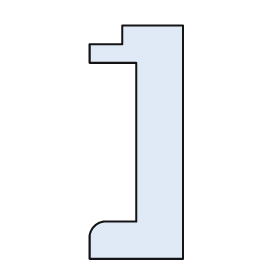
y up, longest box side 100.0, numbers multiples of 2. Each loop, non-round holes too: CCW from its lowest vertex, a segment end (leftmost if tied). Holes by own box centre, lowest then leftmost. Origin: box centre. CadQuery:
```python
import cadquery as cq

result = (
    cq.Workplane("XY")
    .moveTo(-20.0, -50.0)
    .lineTo(20.0, -50.0)
    .lineTo(20.0, 50.0)
    .lineTo(-6.0, 50.0)
    .lineTo(-6.0, 42.0)
    .lineTo(-20.0, 42.0)
    .lineTo(-20.0, 34.0)
    .lineTo(0.0, 34.0)
    .lineTo(0.0, -34.0)
    .lineTo(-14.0, -34.0)
    .threePointArc((-18.0, -36.0), (-20.0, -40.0))
    .close()
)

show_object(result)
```